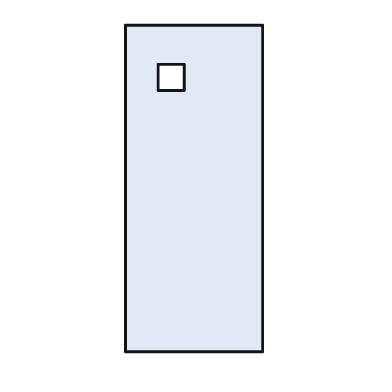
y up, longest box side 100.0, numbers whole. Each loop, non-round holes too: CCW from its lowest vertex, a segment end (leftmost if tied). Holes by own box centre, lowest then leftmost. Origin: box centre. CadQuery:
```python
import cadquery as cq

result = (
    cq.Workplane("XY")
    .moveTo(-21.0, -50.0)
    .lineTo(21.0, -50.0)
    .lineTo(21.0, 50.0)
    .lineTo(-21.0, 50.0)
    .close()
    .moveTo(-11.0, 30.0)
    .lineTo(-3.0, 30.0)
    .lineTo(-3.0, 38.0)
    .lineTo(-11.0, 38.0)
    .close()
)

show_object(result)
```